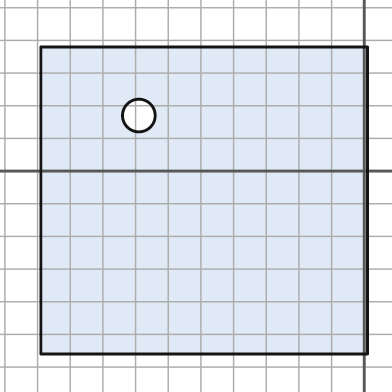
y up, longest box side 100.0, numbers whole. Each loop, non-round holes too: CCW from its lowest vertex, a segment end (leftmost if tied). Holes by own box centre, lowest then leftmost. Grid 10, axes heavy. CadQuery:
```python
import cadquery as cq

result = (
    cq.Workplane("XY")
    .moveTo(-99.0, -56.0)
    .lineTo(1.0, -56.0)
    .lineTo(1.0, 38.0)
    .lineTo(-99.0, 38.0)
    .close()
    .moveTo(-69.0, 17.0)
    .circle(5.0)
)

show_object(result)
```